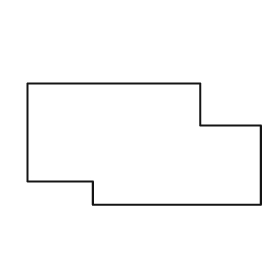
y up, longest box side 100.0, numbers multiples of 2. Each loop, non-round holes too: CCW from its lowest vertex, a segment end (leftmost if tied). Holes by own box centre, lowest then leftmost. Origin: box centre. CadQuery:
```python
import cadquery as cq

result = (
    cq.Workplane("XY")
    .moveTo(-22.0, -26.0)
    .lineTo(50.0, -26.0)
    .lineTo(50.0, 8.0)
    .lineTo(24.0, 8.0)
    .lineTo(24.0, 26.0)
    .lineTo(-50.0, 26.0)
    .lineTo(-50.0, -16.0)
    .lineTo(-22.0, -16.0)
    .close()
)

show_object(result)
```